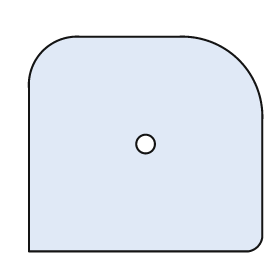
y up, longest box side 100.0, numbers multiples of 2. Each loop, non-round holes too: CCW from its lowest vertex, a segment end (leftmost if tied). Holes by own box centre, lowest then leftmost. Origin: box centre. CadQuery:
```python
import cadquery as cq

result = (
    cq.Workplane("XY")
    .moveTo(-50.0, -46.0)
    .lineTo(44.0, -46.0)
    .threePointArc((48.0, -44.0), (50.0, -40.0))
    .lineTo(50.0, 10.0)
    .threePointArc((40.0, 36.0), (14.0, 46.0))
    .lineTo(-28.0, 46.0)
    .threePointArc((-44.0, 40.0), (-50.0, 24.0))
    .close()
    .moveTo(0.0, 0.0)
    .circle(4.0)
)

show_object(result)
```